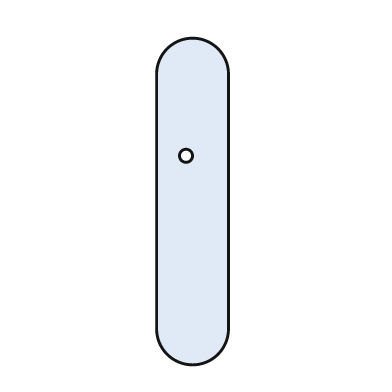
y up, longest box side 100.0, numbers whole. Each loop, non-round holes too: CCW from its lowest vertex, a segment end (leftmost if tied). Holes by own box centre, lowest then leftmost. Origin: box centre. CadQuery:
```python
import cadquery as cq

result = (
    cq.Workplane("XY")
    .moveTo(-11.0, -39.0)
    .threePointArc((0.0, -50.0), (11.0, -39.0))
    .lineTo(11.0, 39.0)
    .threePointArc((0.0, 50.0), (-11.0, 39.0))
    .close()
    .moveTo(-2.0, 14.0)
    .circle(2.0)
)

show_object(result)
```